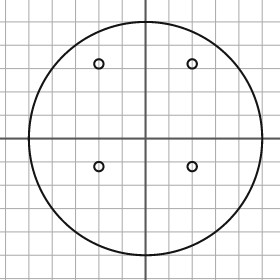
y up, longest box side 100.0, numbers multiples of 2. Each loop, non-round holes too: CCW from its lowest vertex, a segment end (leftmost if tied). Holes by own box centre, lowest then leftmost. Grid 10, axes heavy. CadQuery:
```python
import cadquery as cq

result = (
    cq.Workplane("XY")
    .moveTo(0.0, 0.0)
    .circle(50.0)
    .moveTo(-20.0, -12.0)
    .circle(2.0)
    .moveTo(20.0, -12.0)
    .circle(2.0)
    .moveTo(-20.0, 32.0)
    .circle(2.0)
    .moveTo(20.0, 32.0)
    .circle(2.0)
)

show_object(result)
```